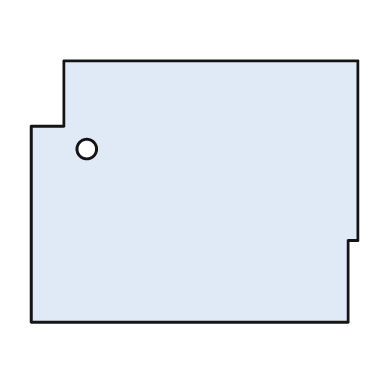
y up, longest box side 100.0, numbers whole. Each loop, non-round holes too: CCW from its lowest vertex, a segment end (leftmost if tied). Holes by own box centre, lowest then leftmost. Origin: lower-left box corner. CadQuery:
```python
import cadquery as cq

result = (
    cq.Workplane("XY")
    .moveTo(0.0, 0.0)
    .lineTo(97.0, 0.0)
    .lineTo(97.0, 25.0)
    .lineTo(100.0, 25.0)
    .lineTo(100.0, 80.0)
    .lineTo(10.0, 80.0)
    .lineTo(10.0, 60.0)
    .lineTo(0.0, 60.0)
    .close()
    .moveTo(17.0, 53.0)
    .circle(3.0)
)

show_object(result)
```